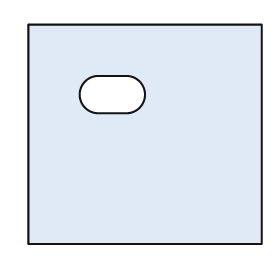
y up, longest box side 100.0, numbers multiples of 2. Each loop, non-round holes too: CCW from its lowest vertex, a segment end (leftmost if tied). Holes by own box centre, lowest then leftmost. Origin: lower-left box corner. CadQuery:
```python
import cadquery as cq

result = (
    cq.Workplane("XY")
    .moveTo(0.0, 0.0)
    .lineTo(100.0, 0.0)
    .lineTo(100.0, 94.0)
    .lineTo(0.0, 94.0)
    .close()
    .moveTo(30.0, 56.0)
    .lineTo(42.0, 56.0)
    .threePointArc((50.0, 64.0), (42.0, 72.0))
    .lineTo(30.0, 72.0)
    .threePointArc((22.0, 64.0), (30.0, 56.0))
    .close()
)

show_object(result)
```